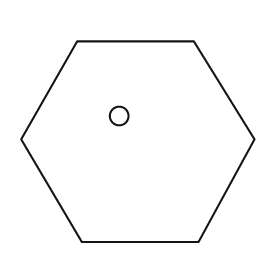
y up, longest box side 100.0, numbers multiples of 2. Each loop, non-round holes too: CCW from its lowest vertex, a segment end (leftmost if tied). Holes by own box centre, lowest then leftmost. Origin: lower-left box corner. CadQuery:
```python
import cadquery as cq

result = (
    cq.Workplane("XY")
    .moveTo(26.0, 0.0)
    .lineTo(76.0, 0.0)
    .lineTo(100.0, 44.0)
    .lineTo(74.0, 86.0)
    .lineTo(24.0, 86.0)
    .lineTo(0.0, 44.0)
    .close()
    .moveTo(42.0, 54.0)
    .circle(4.0)
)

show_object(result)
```